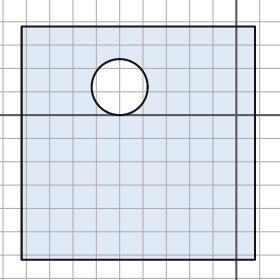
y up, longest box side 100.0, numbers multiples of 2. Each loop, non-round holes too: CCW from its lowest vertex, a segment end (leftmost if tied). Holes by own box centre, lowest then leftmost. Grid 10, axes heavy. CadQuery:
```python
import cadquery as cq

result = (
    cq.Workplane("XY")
    .moveTo(-92.0, -62.0)
    .lineTo(8.0, -62.0)
    .lineTo(8.0, 38.0)
    .lineTo(-92.0, 38.0)
    .close()
    .moveTo(-50.0, 12.0)
    .circle(12.0)
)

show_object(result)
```